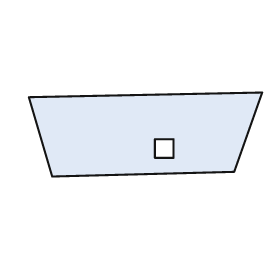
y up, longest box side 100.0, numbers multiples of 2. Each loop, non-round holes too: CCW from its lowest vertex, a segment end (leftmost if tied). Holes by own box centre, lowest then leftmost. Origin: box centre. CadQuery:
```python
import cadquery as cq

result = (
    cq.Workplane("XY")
    .moveTo(-40.0, -18.0)
    .lineTo(38.0, -16.0)
    .lineTo(50.0, 18.0)
    .lineTo(-50.0, 16.0)
    .close()
    .moveTo(4.0, -10.0)
    .lineTo(12.0, -10.0)
    .lineTo(12.0, -2.0)
    .lineTo(4.0, -2.0)
    .close()
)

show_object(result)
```